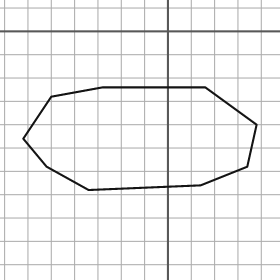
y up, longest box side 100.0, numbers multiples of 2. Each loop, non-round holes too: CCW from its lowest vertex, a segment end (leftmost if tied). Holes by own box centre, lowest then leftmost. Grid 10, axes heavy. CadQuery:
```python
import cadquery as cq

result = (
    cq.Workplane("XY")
    .moveTo(-34.0, -68.0)
    .lineTo(14.0, -66.0)
    .lineTo(34.0, -58.0)
    .lineTo(38.0, -40.0)
    .lineTo(16.0, -24.0)
    .lineTo(-28.0, -24.0)
    .lineTo(-50.0, -28.0)
    .lineTo(-62.0, -46.0)
    .lineTo(-52.0, -58.0)
    .close()
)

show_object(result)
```